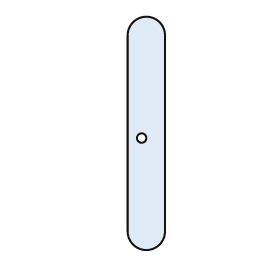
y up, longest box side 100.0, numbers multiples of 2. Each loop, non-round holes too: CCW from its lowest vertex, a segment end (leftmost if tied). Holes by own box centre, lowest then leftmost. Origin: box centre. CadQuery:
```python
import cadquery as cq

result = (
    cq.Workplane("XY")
    .moveTo(-8.0, -42.0)
    .threePointArc((0.0, -50.0), (8.0, -42.0))
    .lineTo(8.0, 42.0)
    .threePointArc((0.0, 50.0), (-8.0, 42.0))
    .close()
    .moveTo(-2.0, -2.0)
    .circle(2.0)
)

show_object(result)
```